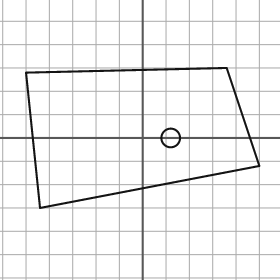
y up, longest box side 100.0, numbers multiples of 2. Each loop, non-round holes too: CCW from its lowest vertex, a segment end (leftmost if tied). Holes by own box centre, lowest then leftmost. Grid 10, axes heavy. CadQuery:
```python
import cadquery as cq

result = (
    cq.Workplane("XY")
    .moveTo(-44.0, -30.0)
    .lineTo(50.0, -12.0)
    .lineTo(36.0, 30.0)
    .lineTo(-50.0, 28.0)
    .close()
    .moveTo(12.0, 0.0)
    .circle(4.0)
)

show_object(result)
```